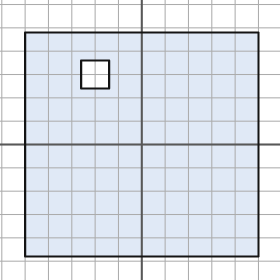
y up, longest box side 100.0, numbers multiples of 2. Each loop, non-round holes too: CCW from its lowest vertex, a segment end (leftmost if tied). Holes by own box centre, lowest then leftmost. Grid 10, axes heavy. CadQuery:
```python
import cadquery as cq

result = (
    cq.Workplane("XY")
    .moveTo(-50.0, -48.0)
    .lineTo(50.0, -48.0)
    .lineTo(50.0, 48.0)
    .lineTo(-50.0, 48.0)
    .close()
    .moveTo(-26.0, 24.0)
    .lineTo(-14.0, 24.0)
    .lineTo(-14.0, 36.0)
    .lineTo(-26.0, 36.0)
    .close()
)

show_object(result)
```